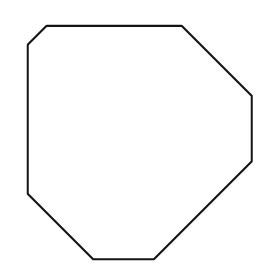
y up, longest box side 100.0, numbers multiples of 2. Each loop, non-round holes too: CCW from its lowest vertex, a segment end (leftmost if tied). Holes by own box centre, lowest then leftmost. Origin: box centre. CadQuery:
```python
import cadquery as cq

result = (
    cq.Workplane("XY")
    .moveTo(-20.0, -50.0)
    .lineTo(6.0, -50.0)
    .lineTo(48.0, -8.0)
    .lineTo(48.0, 20.0)
    .lineTo(18.0, 50.0)
    .lineTo(-40.0, 50.0)
    .lineTo(-48.0, 42.0)
    .lineTo(-48.0, -22.0)
    .close()
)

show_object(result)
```